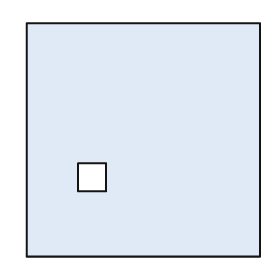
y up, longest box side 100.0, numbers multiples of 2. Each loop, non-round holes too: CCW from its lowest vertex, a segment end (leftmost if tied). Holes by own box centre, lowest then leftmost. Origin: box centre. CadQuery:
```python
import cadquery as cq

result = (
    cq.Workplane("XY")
    .moveTo(-50.0, -50.0)
    .lineTo(50.0, -50.0)
    .lineTo(50.0, 50.0)
    .lineTo(-50.0, 50.0)
    .close()
    .moveTo(-28.0, -22.0)
    .lineTo(-16.0, -22.0)
    .lineTo(-16.0, -10.0)
    .lineTo(-28.0, -10.0)
    .close()
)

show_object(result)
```